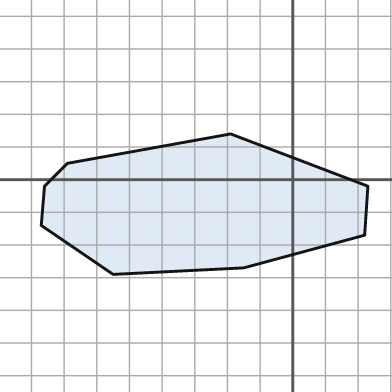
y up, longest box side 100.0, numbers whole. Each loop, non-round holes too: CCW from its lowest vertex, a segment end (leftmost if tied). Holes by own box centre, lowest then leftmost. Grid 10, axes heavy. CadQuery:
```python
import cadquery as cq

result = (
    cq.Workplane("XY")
    .moveTo(-55.0, -29.0)
    .lineTo(-15.0, -27.0)
    .lineTo(22.0, -17.0)
    .lineTo(23.0, -2.0)
    .lineTo(-19.0, 14.0)
    .lineTo(-69.0, 5.0)
    .lineTo(-76.0, -2.0)
    .lineTo(-77.0, -14.0)
    .close()
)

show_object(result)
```